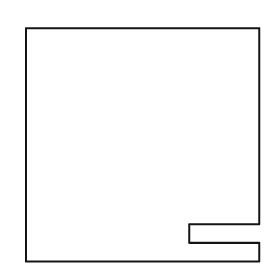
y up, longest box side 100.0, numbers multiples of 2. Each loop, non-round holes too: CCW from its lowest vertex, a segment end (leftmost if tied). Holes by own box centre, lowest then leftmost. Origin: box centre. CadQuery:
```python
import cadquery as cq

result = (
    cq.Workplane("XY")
    .moveTo(-50.0, -50.0)
    .lineTo(50.0, -50.0)
    .lineTo(50.0, -42.0)
    .lineTo(20.0, -42.0)
    .lineTo(20.0, -34.0)
    .lineTo(50.0, -34.0)
    .lineTo(50.0, 50.0)
    .lineTo(-50.0, 50.0)
    .close()
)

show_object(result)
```